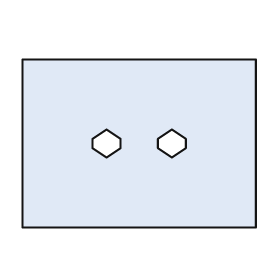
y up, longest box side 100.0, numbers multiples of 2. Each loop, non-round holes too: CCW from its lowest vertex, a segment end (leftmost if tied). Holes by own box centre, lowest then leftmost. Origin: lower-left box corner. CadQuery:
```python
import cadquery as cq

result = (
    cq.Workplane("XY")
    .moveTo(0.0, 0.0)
    .lineTo(100.0, 0.0)
    .lineTo(100.0, 72.0)
    .lineTo(0.0, 72.0)
    .close()
    .moveTo(36.0, 30.0)
    .lineTo(42.0, 34.0)
    .lineTo(42.0, 38.0)
    .lineTo(36.0, 42.0)
    .lineTo(30.0, 38.0)
    .lineTo(30.0, 34.0)
    .close()
    .moveTo(64.0, 30.0)
    .lineTo(70.0, 34.0)
    .lineTo(70.0, 38.0)
    .lineTo(64.0, 42.0)
    .lineTo(58.0, 38.0)
    .lineTo(58.0, 34.0)
    .close()
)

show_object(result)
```